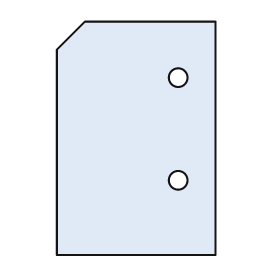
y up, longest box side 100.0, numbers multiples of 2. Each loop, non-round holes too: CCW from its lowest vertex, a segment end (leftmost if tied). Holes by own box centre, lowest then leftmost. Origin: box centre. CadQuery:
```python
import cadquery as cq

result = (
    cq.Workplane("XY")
    .moveTo(-34.0, -50.0)
    .lineTo(34.0, -50.0)
    .lineTo(34.0, 50.0)
    .lineTo(-22.0, 50.0)
    .lineTo(-34.0, 38.0)
    .close()
    .moveTo(18.0, -18.0)
    .circle(4.0)
    .moveTo(18.0, 26.0)
    .circle(4.0)
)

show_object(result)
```